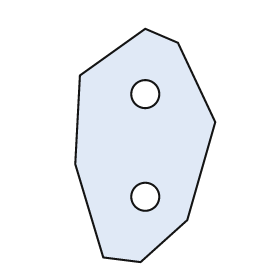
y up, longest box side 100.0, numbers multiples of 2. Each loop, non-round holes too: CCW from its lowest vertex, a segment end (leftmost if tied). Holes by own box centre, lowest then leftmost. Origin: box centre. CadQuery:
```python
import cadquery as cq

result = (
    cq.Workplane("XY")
    .moveTo(-2.0, -50.0)
    .lineTo(18.0, -32.0)
    .lineTo(30.0, 10.0)
    .lineTo(14.0, 44.0)
    .lineTo(0.0, 50.0)
    .lineTo(-28.0, 30.0)
    .lineTo(-30.0, -8.0)
    .lineTo(-18.0, -48.0)
    .close()
    .moveTo(0.0, -22.0)
    .circle(6.0)
    .moveTo(0.0, 22.0)
    .circle(6.0)
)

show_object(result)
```